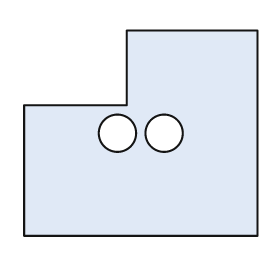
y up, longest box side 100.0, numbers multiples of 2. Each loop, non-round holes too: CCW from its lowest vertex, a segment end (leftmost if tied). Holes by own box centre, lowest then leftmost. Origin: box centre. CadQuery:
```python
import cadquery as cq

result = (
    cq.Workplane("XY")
    .moveTo(-50.0, -44.0)
    .lineTo(50.0, -44.0)
    .lineTo(50.0, 44.0)
    .lineTo(-6.0, 44.0)
    .lineTo(-6.0, 12.0)
    .lineTo(-50.0, 12.0)
    .close()
    .moveTo(-10.0, 0.0)
    .circle(8.0)
    .moveTo(10.0, 0.0)
    .circle(8.0)
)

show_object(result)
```